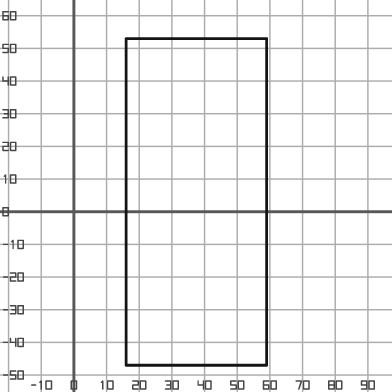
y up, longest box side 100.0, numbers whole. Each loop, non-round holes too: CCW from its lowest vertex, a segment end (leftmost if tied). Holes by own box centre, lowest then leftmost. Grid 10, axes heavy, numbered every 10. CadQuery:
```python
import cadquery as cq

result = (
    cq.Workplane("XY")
    .moveTo(16.0, -47.0)
    .lineTo(59.0, -47.0)
    .lineTo(59.0, 53.0)
    .lineTo(16.0, 53.0)
    .close()
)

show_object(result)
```